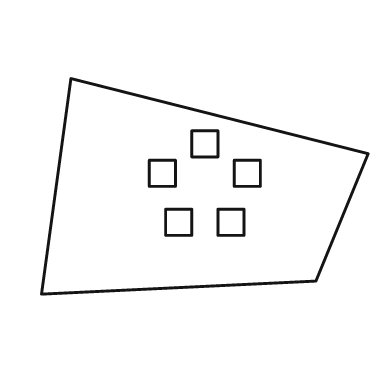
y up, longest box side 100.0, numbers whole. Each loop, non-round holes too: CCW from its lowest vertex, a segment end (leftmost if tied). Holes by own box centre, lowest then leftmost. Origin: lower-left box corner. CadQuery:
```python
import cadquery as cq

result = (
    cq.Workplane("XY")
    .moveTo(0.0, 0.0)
    .lineTo(84.0, 4.0)
    .lineTo(100.0, 43.0)
    .lineTo(9.0, 66.0)
    .close()
    .moveTo(38.0, 18.0)
    .lineTo(46.0, 18.0)
    .lineTo(46.0, 26.0)
    .lineTo(38.0, 26.0)
    .close()
    .moveTo(54.0, 18.0)
    .lineTo(62.0, 18.0)
    .lineTo(62.0, 26.0)
    .lineTo(54.0, 26.0)
    .close()
    .moveTo(33.0, 33.0)
    .lineTo(41.0, 33.0)
    .lineTo(41.0, 41.0)
    .lineTo(33.0, 41.0)
    .close()
    .moveTo(59.0, 33.0)
    .lineTo(67.0, 33.0)
    .lineTo(67.0, 41.0)
    .lineTo(59.0, 41.0)
    .close()
    .moveTo(46.0, 42.0)
    .lineTo(54.0, 42.0)
    .lineTo(54.0, 50.0)
    .lineTo(46.0, 50.0)
    .close()
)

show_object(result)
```